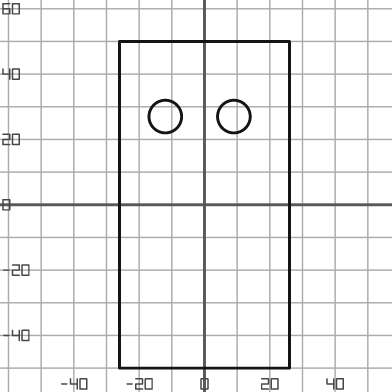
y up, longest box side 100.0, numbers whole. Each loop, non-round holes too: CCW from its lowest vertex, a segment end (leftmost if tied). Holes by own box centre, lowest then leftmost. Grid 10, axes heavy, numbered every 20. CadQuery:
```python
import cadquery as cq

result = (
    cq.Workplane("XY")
    .moveTo(-26.0, -50.0)
    .lineTo(26.0, -50.0)
    .lineTo(26.0, 50.0)
    .lineTo(-26.0, 50.0)
    .close()
    .moveTo(-12.0, 27.0)
    .circle(5.0)
    .moveTo(9.0, 27.0)
    .circle(5.0)
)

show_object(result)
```